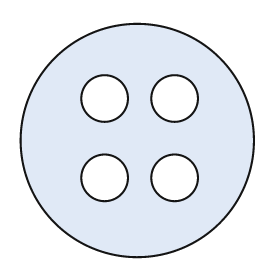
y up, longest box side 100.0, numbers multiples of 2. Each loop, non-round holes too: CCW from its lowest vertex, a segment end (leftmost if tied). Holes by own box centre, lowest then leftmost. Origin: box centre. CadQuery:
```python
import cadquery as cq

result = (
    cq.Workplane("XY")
    .moveTo(0.0, 0.0)
    .circle(50.0)
    .moveTo(-14.0, -16.0)
    .circle(10.0)
    .moveTo(16.0, -16.0)
    .circle(10.0)
    .moveTo(-14.0, 18.0)
    .circle(10.0)
    .moveTo(16.0, 18.0)
    .circle(10.0)
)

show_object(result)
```